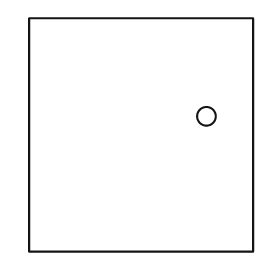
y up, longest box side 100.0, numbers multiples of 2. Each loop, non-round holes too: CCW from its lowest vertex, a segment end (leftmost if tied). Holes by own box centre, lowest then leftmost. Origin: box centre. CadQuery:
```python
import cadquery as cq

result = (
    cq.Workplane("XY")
    .moveTo(-48.0, -50.0)
    .lineTo(48.0, -50.0)
    .lineTo(48.0, 50.0)
    .lineTo(-48.0, 50.0)
    .close()
    .moveTo(28.0, 8.0)
    .circle(4.0)
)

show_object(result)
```